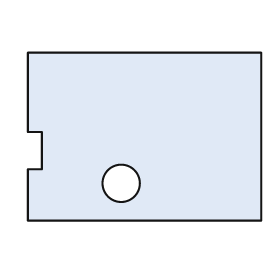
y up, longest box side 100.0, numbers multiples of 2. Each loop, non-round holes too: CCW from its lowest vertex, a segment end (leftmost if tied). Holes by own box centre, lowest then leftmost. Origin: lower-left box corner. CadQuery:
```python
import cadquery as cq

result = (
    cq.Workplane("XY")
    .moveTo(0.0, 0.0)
    .lineTo(100.0, 0.0)
    .lineTo(100.0, 72.0)
    .lineTo(0.0, 72.0)
    .lineTo(0.0, 38.0)
    .lineTo(6.0, 38.0)
    .lineTo(6.0, 22.0)
    .lineTo(0.0, 22.0)
    .close()
    .moveTo(40.0, 16.0)
    .circle(8.0)
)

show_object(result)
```